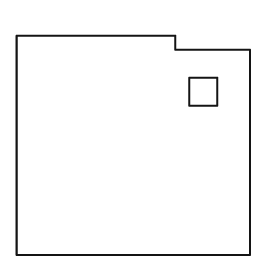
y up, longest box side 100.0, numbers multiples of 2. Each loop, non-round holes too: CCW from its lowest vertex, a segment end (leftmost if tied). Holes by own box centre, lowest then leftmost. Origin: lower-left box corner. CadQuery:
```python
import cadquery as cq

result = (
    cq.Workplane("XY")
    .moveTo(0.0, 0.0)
    .lineTo(100.0, 0.0)
    .lineTo(100.0, 88.0)
    .lineTo(68.0, 88.0)
    .lineTo(68.0, 94.0)
    .lineTo(0.0, 94.0)
    .close()
    .moveTo(74.0, 64.0)
    .lineTo(86.0, 64.0)
    .lineTo(86.0, 76.0)
    .lineTo(74.0, 76.0)
    .close()
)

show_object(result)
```